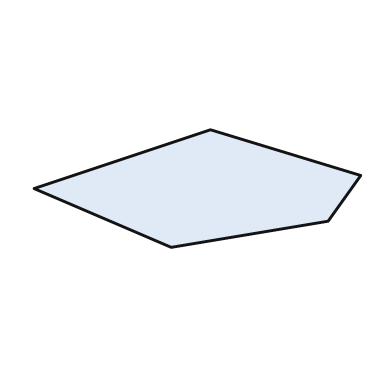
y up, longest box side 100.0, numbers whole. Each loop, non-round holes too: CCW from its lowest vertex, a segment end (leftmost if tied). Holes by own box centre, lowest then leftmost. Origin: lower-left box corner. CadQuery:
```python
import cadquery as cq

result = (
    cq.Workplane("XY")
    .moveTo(42.0, 0.0)
    .lineTo(90.0, 8.0)
    .lineTo(100.0, 22.0)
    .lineTo(54.0, 36.0)
    .lineTo(0.0, 18.0)
    .close()
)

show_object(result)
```